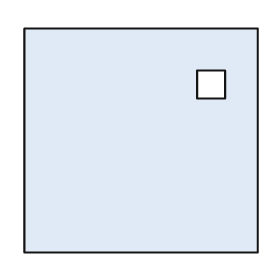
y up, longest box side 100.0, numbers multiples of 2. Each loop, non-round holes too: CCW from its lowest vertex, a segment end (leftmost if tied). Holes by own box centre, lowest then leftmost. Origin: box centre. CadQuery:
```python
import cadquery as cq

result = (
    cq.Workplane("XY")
    .moveTo(-50.0, -48.0)
    .lineTo(50.0, -48.0)
    .lineTo(50.0, 48.0)
    .lineTo(-50.0, 48.0)
    .close()
    .moveTo(24.0, 18.0)
    .lineTo(36.0, 18.0)
    .lineTo(36.0, 30.0)
    .lineTo(24.0, 30.0)
    .close()
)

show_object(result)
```